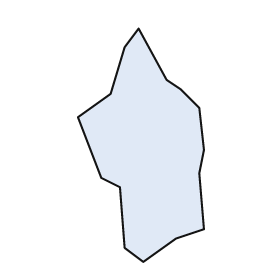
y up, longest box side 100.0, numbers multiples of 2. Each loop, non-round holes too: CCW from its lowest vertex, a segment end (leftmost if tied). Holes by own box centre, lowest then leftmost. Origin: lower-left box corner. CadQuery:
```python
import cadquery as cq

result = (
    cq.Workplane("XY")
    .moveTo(28.0, 0.0)
    .lineTo(42.0, 10.0)
    .lineTo(54.0, 14.0)
    .lineTo(52.0, 38.0)
    .lineTo(54.0, 48.0)
    .lineTo(52.0, 66.0)
    .lineTo(44.0, 74.0)
    .lineTo(38.0, 78.0)
    .lineTo(26.0, 100.0)
    .lineTo(20.0, 92.0)
    .lineTo(14.0, 72.0)
    .lineTo(0.0, 62.0)
    .lineTo(10.0, 36.0)
    .lineTo(18.0, 32.0)
    .lineTo(20.0, 6.0)
    .close()
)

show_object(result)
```